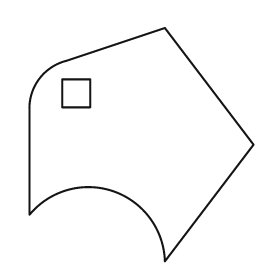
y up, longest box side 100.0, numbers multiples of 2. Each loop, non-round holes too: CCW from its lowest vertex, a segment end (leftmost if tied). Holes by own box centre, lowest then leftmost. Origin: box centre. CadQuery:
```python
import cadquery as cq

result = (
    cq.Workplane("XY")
    .moveTo(10.0, -50.0)
    .lineTo(48.0, 0.0)
    .lineTo(10.0, 50.0)
    .lineTo(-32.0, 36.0)
    .threePointArc((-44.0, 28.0), (-48.0, 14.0))
    .lineTo(-48.0, -30.0)
    .threePointArc((-12.0, -20.0), (10.0, -50.0))
    .close()
    .moveTo(-34.0, 16.0)
    .lineTo(-22.0, 16.0)
    .lineTo(-22.0, 28.0)
    .lineTo(-34.0, 28.0)
    .close()
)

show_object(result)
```